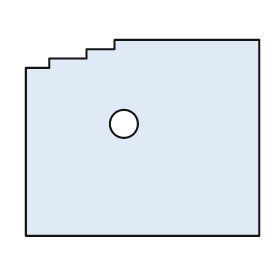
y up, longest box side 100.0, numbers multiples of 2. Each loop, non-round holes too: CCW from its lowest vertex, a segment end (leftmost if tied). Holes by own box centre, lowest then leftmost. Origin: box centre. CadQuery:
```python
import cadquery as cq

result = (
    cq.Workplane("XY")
    .moveTo(-50.0, -42.0)
    .lineTo(50.0, -42.0)
    .lineTo(50.0, 42.0)
    .lineTo(-12.0, 42.0)
    .lineTo(-12.0, 38.0)
    .lineTo(-24.0, 38.0)
    .lineTo(-24.0, 34.0)
    .lineTo(-40.0, 34.0)
    .lineTo(-40.0, 30.0)
    .lineTo(-50.0, 30.0)
    .close()
    .moveTo(-8.0, 6.0)
    .circle(6.0)
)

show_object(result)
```